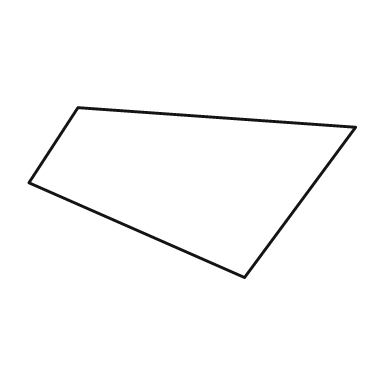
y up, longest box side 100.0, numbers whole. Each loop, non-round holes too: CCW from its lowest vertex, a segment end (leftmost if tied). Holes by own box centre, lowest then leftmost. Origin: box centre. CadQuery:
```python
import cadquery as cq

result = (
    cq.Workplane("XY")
    .moveTo(16.0, -26.0)
    .lineTo(50.0, 20.0)
    .lineTo(-35.0, 26.0)
    .lineTo(-50.0, 3.0)
    .close()
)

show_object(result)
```